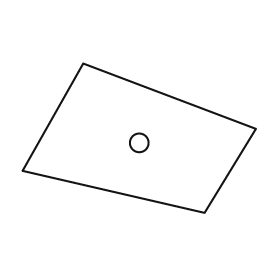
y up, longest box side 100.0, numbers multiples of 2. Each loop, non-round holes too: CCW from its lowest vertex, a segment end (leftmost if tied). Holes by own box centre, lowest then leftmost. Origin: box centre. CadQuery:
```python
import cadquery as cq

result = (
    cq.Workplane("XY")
    .moveTo(28.0, -32.0)
    .lineTo(50.0, 4.0)
    .lineTo(-24.0, 32.0)
    .lineTo(-50.0, -14.0)
    .close()
    .moveTo(0.0, -2.0)
    .circle(4.0)
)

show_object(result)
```